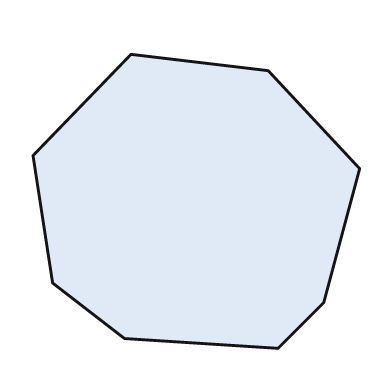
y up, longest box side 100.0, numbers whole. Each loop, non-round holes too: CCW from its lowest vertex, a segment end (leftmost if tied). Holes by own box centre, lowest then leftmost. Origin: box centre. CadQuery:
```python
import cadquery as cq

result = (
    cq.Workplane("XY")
    .moveTo(25.0, -45.0)
    .lineTo(39.0, -31.0)
    .lineTo(50.0, 10.0)
    .lineTo(22.0, 40.0)
    .lineTo(-20.0, 45.0)
    .lineTo(-50.0, 14.0)
    .lineTo(-44.0, -25.0)
    .lineTo(-22.0, -42.0)
    .close()
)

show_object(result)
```